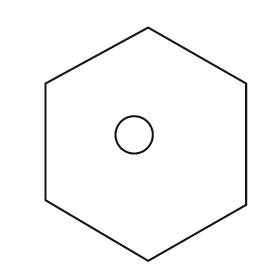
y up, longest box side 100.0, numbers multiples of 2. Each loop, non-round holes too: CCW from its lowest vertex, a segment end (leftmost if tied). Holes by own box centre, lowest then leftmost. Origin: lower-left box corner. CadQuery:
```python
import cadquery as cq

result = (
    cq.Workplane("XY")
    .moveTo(44.0, 0.0)
    .lineTo(86.0, 24.0)
    .lineTo(86.0, 76.0)
    .lineTo(44.0, 100.0)
    .lineTo(0.0, 76.0)
    .lineTo(0.0, 26.0)
    .close()
    .moveTo(38.0, 54.0)
    .circle(8.0)
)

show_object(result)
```